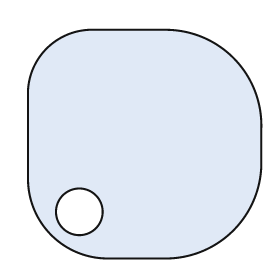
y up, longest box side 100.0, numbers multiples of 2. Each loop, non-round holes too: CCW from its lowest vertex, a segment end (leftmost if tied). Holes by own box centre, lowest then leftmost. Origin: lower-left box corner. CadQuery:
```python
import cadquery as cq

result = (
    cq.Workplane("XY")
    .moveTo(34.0, 0.0)
    .lineTo(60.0, 0.0)
    .threePointArc((88.0, 12.0), (100.0, 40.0))
    .lineTo(100.0, 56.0)
    .threePointArc((88.0, 86.0), (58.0, 98.0))
    .lineTo(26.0, 98.0)
    .threePointArc((8.0, 90.0), (0.0, 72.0))
    .lineTo(0.0, 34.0)
    .threePointArc((10.0, 10.0), (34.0, 0.0))
    .close()
    .moveTo(22.0, 20.0)
    .circle(10.0)
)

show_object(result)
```